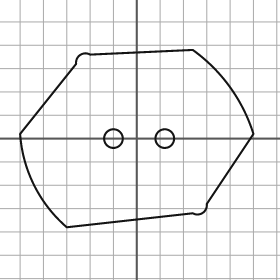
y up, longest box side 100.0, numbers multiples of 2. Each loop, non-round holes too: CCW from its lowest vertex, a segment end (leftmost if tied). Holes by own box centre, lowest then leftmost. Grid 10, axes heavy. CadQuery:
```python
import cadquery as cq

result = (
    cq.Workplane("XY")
    .moveTo(-30.0, -38.0)
    .lineTo(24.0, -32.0)
    .threePointArc((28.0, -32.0), (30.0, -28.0))
    .lineTo(50.0, 2.0)
    .threePointArc((40.0, 22.0), (24.0, 38.0))
    .lineTo(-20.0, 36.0)
    .threePointArc((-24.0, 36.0), (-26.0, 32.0))
    .lineTo(-50.0, 2.0)
    .threePointArc((-44.0, -20.0), (-30.0, -38.0))
    .close()
    .moveTo(-10.0, 0.0)
    .circle(4.0)
    .moveTo(12.0, 0.0)
    .circle(4.0)
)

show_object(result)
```